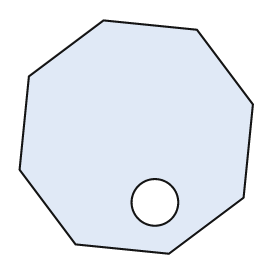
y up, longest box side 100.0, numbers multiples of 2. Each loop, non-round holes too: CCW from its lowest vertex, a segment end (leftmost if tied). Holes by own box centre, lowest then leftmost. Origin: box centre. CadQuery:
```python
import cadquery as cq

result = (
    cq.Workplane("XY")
    .moveTo(14.0, -50.0)
    .lineTo(46.0, -26.0)
    .lineTo(50.0, 14.0)
    .lineTo(26.0, 46.0)
    .lineTo(-14.0, 50.0)
    .lineTo(-46.0, 26.0)
    .lineTo(-50.0, -14.0)
    .lineTo(-26.0, -46.0)
    .close()
    .moveTo(8.0, -28.0)
    .circle(10.0)
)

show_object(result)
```